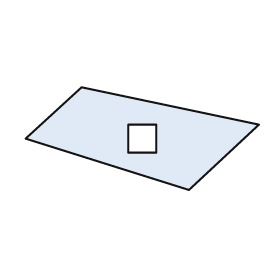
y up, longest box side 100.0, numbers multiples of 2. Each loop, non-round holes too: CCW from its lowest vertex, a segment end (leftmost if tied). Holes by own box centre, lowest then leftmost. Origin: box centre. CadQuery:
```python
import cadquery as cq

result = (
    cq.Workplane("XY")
    .moveTo(20.0, -22.0)
    .lineTo(50.0, 6.0)
    .lineTo(-26.0, 22.0)
    .lineTo(-50.0, 0.0)
    .close()
    .moveTo(-6.0, -6.0)
    .lineTo(6.0, -6.0)
    .lineTo(6.0, 6.0)
    .lineTo(-6.0, 6.0)
    .close()
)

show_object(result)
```